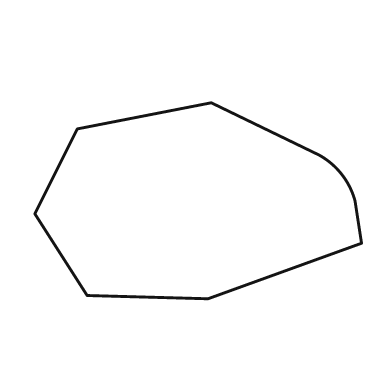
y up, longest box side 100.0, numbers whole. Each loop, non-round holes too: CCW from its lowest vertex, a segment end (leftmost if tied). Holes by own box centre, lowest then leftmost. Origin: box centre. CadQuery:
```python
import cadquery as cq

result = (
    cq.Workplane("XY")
    .moveTo(3.0, -30.0)
    .lineTo(50.0, -13.0)
    .lineTo(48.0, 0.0)
    .threePointArc((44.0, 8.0), (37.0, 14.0))
    .lineTo(4.0, 30.0)
    .lineTo(-37.0, 22.0)
    .lineTo(-50.0, -4.0)
    .lineTo(-34.0, -29.0)
    .close()
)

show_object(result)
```